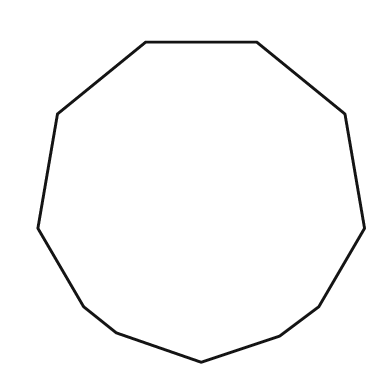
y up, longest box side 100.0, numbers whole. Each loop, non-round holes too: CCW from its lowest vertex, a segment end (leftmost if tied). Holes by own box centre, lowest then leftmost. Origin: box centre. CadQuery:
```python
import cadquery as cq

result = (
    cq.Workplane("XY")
    .moveTo(0.0, -49.0)
    .lineTo(24.0, -41.0)
    .lineTo(36.0, -32.0)
    .lineTo(50.0, -8.0)
    .lineTo(44.0, 27.0)
    .lineTo(17.0, 49.0)
    .lineTo(-17.0, 49.0)
    .lineTo(-44.0, 27.0)
    .lineTo(-50.0, -8.0)
    .lineTo(-36.0, -32.0)
    .lineTo(-26.0, -40.0)
    .close()
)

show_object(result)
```